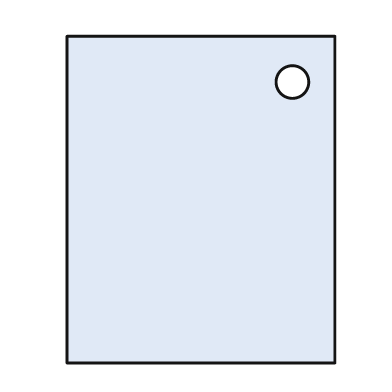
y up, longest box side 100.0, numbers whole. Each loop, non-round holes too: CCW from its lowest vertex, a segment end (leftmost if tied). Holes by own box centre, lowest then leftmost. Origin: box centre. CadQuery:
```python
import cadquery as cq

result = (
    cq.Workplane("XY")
    .moveTo(-41.0, -50.0)
    .lineTo(41.0, -50.0)
    .lineTo(41.0, 50.0)
    .lineTo(-41.0, 50.0)
    .close()
    .moveTo(28.0, 36.0)
    .circle(5.0)
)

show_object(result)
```